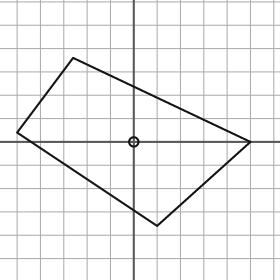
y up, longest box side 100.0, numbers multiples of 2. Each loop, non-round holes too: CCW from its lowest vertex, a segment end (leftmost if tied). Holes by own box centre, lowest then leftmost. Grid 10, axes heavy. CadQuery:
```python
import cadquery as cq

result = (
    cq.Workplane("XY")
    .moveTo(10.0, -36.0)
    .lineTo(50.0, 0.0)
    .lineTo(-26.0, 36.0)
    .lineTo(-50.0, 4.0)
    .close()
    .moveTo(0.0, 0.0)
    .circle(2.0)
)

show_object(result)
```